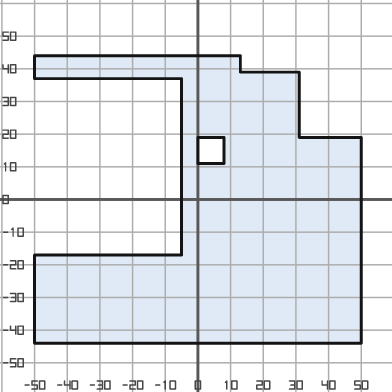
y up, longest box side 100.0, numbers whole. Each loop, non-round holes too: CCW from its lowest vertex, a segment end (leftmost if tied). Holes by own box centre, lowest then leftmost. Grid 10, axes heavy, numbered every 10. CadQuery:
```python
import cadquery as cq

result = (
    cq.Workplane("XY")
    .moveTo(-50.0, -44.0)
    .lineTo(50.0, -44.0)
    .lineTo(50.0, 19.0)
    .lineTo(31.0, 19.0)
    .lineTo(31.0, 39.0)
    .lineTo(13.0, 39.0)
    .lineTo(13.0, 44.0)
    .lineTo(-50.0, 44.0)
    .lineTo(-50.0, 37.0)
    .lineTo(-5.0, 37.0)
    .lineTo(-5.0, -17.0)
    .lineTo(-50.0, -17.0)
    .close()
    .moveTo(0.0, 11.0)
    .lineTo(8.0, 11.0)
    .lineTo(8.0, 19.0)
    .lineTo(0.0, 19.0)
    .close()
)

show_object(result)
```